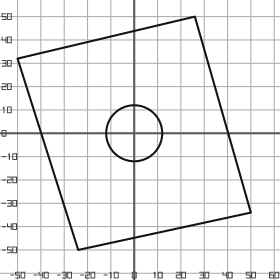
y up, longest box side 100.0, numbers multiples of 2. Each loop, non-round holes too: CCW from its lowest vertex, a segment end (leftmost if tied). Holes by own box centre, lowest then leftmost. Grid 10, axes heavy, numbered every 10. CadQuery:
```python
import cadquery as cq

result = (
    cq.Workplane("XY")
    .moveTo(-24.0, -50.0)
    .lineTo(50.0, -34.0)
    .lineTo(26.0, 50.0)
    .lineTo(-50.0, 32.0)
    .close()
    .moveTo(0.0, 0.0)
    .circle(12.0)
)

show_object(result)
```